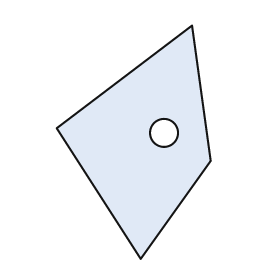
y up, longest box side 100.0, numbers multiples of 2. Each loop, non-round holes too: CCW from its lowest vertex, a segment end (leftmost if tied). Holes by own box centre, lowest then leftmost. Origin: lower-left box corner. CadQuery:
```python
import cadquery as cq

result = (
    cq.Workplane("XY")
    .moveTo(36.0, 0.0)
    .lineTo(66.0, 42.0)
    .lineTo(58.0, 100.0)
    .lineTo(0.0, 56.0)
    .close()
    .moveTo(46.0, 54.0)
    .circle(6.0)
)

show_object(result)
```